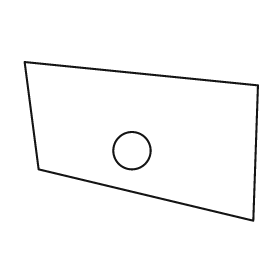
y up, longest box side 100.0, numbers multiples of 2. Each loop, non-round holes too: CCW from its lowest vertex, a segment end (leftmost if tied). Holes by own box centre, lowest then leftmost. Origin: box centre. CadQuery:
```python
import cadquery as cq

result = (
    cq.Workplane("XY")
    .moveTo(48.0, -34.0)
    .lineTo(50.0, 24.0)
    .lineTo(-50.0, 34.0)
    .lineTo(-44.0, -12.0)
    .close()
    .moveTo(-4.0, -4.0)
    .circle(8.0)
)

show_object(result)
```